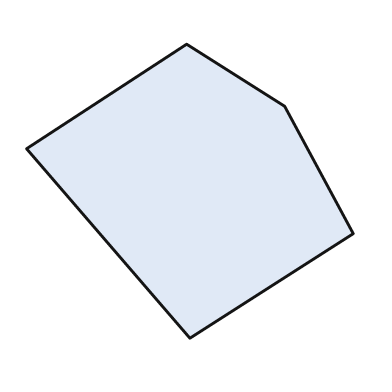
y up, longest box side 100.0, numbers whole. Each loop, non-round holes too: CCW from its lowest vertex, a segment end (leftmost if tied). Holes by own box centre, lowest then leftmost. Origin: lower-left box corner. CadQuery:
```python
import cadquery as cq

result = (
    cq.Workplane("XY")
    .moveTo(50.0, 0.0)
    .lineTo(100.0, 32.0)
    .lineTo(79.0, 71.0)
    .lineTo(49.0, 90.0)
    .lineTo(0.0, 58.0)
    .close()
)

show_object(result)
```